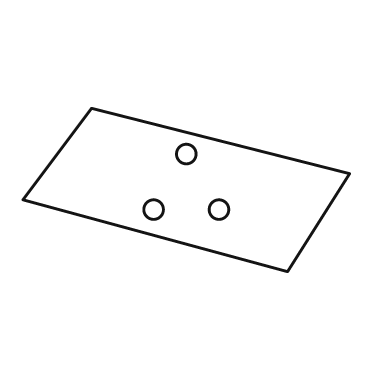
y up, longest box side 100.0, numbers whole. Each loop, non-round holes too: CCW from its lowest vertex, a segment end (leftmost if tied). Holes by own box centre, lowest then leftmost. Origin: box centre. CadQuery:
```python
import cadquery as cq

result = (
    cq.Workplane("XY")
    .moveTo(31.0, -25.0)
    .lineTo(50.0, 5.0)
    .lineTo(-29.0, 25.0)
    .lineTo(-50.0, -3.0)
    .close()
    .moveTo(-10.0, -6.0)
    .circle(3.0)
    .moveTo(10.0, -6.0)
    .circle(3.0)
    .moveTo(0.0, 11.0)
    .circle(3.0)
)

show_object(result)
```